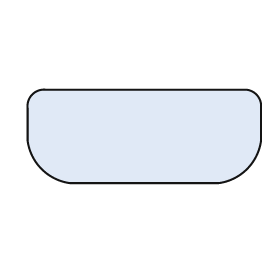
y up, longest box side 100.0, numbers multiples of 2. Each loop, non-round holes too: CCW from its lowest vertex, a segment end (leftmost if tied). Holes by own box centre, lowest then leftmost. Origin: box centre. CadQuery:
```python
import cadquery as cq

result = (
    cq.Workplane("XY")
    .moveTo(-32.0, -20.0)
    .lineTo(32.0, -20.0)
    .threePointArc((44.0, -14.0), (50.0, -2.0))
    .lineTo(50.0, 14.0)
    .threePointArc((48.0, 18.0), (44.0, 20.0))
    .lineTo(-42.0, 20.0)
    .threePointArc((-48.0, 18.0), (-50.0, 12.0))
    .lineTo(-50.0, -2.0)
    .threePointArc((-44.0, -14.0), (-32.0, -20.0))
    .close()
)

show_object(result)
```